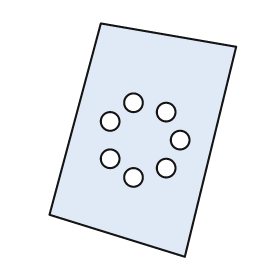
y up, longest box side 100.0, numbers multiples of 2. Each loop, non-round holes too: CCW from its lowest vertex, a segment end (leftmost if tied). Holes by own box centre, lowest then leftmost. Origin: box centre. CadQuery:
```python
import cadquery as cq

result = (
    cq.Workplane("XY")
    .moveTo(18.0, -50.0)
    .lineTo(40.0, 40.0)
    .lineTo(-18.0, 50.0)
    .lineTo(-40.0, -32.0)
    .close()
    .moveTo(-4.0, -16.0)
    .circle(4.0)
    .moveTo(10.0, -12.0)
    .circle(4.0)
    .moveTo(-14.0, -8.0)
    .circle(4.0)
    .moveTo(16.0, 0.0)
    .circle(4.0)
    .moveTo(-14.0, 8.0)
    .circle(4.0)
    .moveTo(10.0, 12.0)
    .circle(4.0)
    .moveTo(-4.0, 16.0)
    .circle(4.0)
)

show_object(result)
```